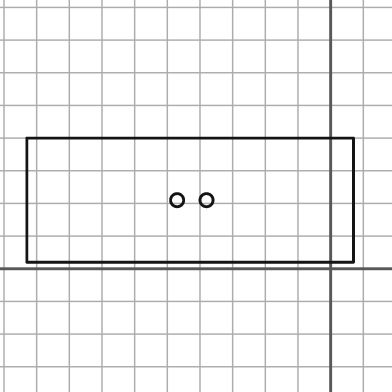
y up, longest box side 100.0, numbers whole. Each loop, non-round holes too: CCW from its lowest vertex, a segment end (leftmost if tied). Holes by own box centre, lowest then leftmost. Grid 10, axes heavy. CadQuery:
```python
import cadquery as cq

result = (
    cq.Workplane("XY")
    .moveTo(-93.0, 2.0)
    .lineTo(7.0, 2.0)
    .lineTo(7.0, 40.0)
    .lineTo(-93.0, 40.0)
    .close()
    .moveTo(-47.0, 21.0)
    .circle(2.0)
    .moveTo(-38.0, 21.0)
    .circle(2.0)
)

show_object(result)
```